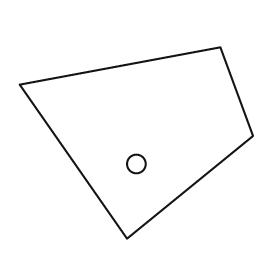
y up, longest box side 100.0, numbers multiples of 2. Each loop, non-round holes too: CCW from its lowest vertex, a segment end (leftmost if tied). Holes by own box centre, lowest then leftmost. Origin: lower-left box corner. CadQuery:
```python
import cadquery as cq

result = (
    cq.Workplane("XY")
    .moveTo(46.0, 0.0)
    .lineTo(100.0, 44.0)
    .lineTo(86.0, 82.0)
    .lineTo(0.0, 66.0)
    .close()
    .moveTo(50.0, 32.0)
    .circle(4.0)
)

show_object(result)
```